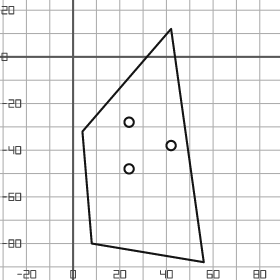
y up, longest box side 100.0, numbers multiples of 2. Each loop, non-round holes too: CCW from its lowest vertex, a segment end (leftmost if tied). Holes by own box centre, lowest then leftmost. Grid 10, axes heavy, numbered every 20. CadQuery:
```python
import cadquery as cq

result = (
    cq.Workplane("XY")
    .moveTo(56.0, -88.0)
    .lineTo(42.0, 12.0)
    .lineTo(4.0, -32.0)
    .lineTo(8.0, -80.0)
    .close()
    .moveTo(24.0, -48.0)
    .circle(2.0)
    .moveTo(42.0, -38.0)
    .circle(2.0)
    .moveTo(24.0, -28.0)
    .circle(2.0)
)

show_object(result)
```